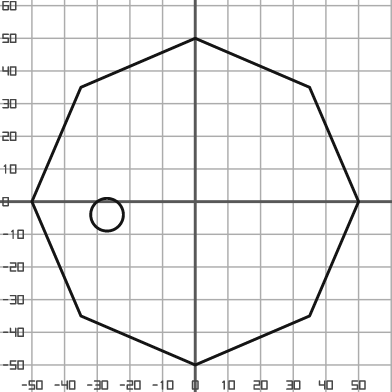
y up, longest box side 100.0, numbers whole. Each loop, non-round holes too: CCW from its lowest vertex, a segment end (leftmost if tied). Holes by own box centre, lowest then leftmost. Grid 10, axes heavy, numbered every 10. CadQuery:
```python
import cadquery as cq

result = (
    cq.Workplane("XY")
    .moveTo(0.0, -50.0)
    .lineTo(35.0, -35.0)
    .lineTo(50.0, 0.0)
    .lineTo(35.0, 35.0)
    .lineTo(0.0, 50.0)
    .lineTo(-35.0, 35.0)
    .lineTo(-50.0, 0.0)
    .lineTo(-35.0, -35.0)
    .close()
    .moveTo(-27.0, -4.0)
    .circle(5.0)
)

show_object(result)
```